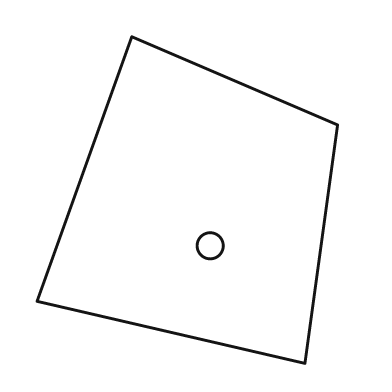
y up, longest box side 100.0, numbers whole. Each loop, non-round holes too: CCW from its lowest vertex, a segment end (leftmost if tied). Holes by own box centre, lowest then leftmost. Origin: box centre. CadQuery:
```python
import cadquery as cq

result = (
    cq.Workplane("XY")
    .moveTo(36.0, -50.0)
    .lineTo(46.0, 23.0)
    .lineTo(-17.0, 50.0)
    .lineTo(-46.0, -31.0)
    .close()
    .moveTo(7.0, -14.0)
    .circle(4.0)
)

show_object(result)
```